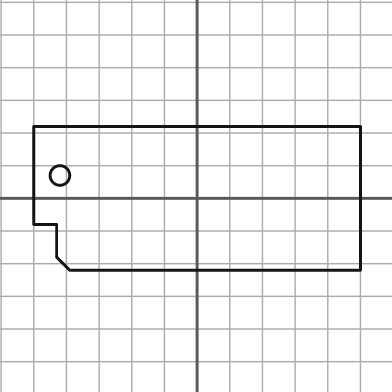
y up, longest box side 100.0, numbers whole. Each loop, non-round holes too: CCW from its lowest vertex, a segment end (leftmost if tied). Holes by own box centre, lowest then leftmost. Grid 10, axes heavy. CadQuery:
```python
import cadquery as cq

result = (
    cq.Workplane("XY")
    .moveTo(-39.0, -22.0)
    .lineTo(50.0, -22.0)
    .lineTo(50.0, 22.0)
    .lineTo(-50.0, 22.0)
    .lineTo(-50.0, -8.0)
    .lineTo(-43.0, -8.0)
    .lineTo(-43.0, -18.0)
    .close()
    .moveTo(-42.0, 7.0)
    .circle(3.0)
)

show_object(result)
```